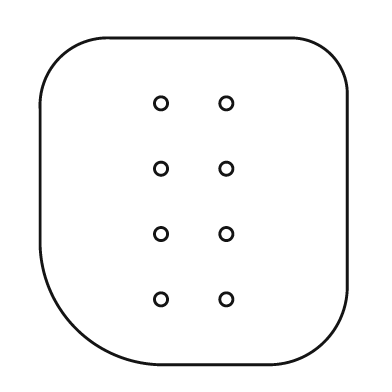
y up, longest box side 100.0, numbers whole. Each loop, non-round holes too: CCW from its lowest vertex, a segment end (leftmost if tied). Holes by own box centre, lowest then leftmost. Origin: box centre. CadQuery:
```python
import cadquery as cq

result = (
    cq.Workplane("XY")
    .moveTo(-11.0, -50.0)
    .lineTo(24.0, -50.0)
    .threePointArc((40.0, -43.0), (47.0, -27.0))
    .lineTo(47.0, 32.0)
    .threePointArc((42.0, 45.0), (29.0, 50.0))
    .lineTo(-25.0, 50.0)
    .threePointArc((-41.0, 44.0), (-47.0, 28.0))
    .lineTo(-47.0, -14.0)
    .threePointArc((-36.0, -39.0), (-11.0, -50.0))
    .close()
    .moveTo(-10.0, -30.0)
    .circle(2.0)
    .moveTo(10.0, -30.0)
    .circle(2.0)
    .moveTo(-10.0, -10.0)
    .circle(2.0)
    .moveTo(10.0, -10.0)
    .circle(2.0)
    .moveTo(-10.0, 10.0)
    .circle(2.0)
    .moveTo(10.0, 10.0)
    .circle(2.0)
    .moveTo(-10.0, 30.0)
    .circle(2.0)
    .moveTo(10.0, 30.0)
    .circle(2.0)
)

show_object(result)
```